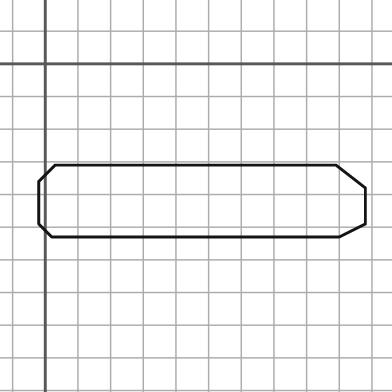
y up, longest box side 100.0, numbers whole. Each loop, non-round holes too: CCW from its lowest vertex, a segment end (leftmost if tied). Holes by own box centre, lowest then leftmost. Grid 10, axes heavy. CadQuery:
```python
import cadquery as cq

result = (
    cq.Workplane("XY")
    .moveTo(2.0, -53.0)
    .lineTo(90.0, -53.0)
    .lineTo(98.0, -49.0)
    .lineTo(98.0, -38.0)
    .lineTo(89.0, -31.0)
    .lineTo(3.0, -31.0)
    .lineTo(-2.0, -36.0)
    .lineTo(-2.0, -49.0)
    .close()
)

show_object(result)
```